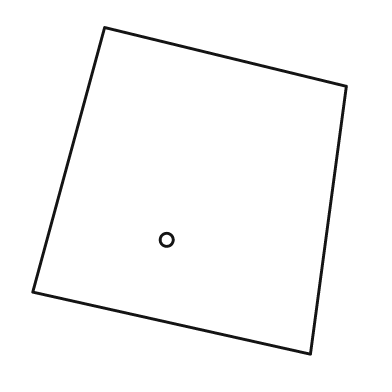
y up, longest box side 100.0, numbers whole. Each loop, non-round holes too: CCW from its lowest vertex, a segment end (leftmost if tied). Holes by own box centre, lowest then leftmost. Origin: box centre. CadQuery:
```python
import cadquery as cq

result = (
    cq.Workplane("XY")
    .moveTo(37.0, -50.0)
    .lineTo(48.0, 32.0)
    .lineTo(-26.0, 50.0)
    .lineTo(-48.0, -31.0)
    .close()
    .moveTo(-7.0, -15.0)
    .circle(2.0)
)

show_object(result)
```